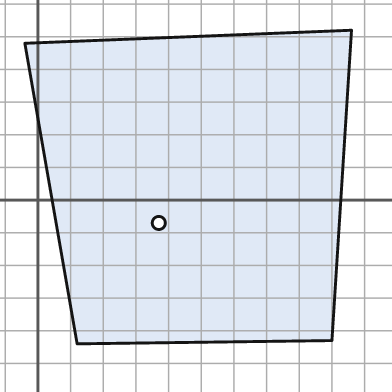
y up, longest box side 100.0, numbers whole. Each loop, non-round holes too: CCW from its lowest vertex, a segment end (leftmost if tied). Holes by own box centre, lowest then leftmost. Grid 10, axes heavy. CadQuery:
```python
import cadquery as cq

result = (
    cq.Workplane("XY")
    .moveTo(12.0, -44.0)
    .lineTo(90.0, -43.0)
    .lineTo(96.0, 52.0)
    .lineTo(-4.0, 48.0)
    .close()
    .moveTo(37.0, -7.0)
    .circle(2.0)
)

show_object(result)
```